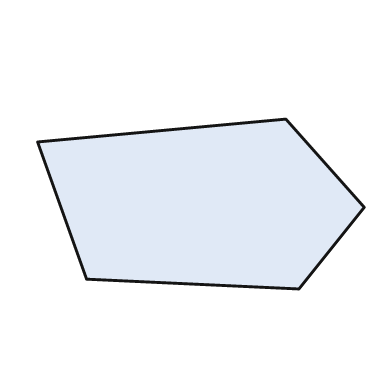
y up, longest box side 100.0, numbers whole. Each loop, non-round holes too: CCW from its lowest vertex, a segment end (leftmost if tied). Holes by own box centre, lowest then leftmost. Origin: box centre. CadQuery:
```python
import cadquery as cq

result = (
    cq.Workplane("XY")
    .moveTo(30.0, -26.0)
    .lineTo(50.0, -1.0)
    .lineTo(26.0, 26.0)
    .lineTo(-50.0, 19.0)
    .lineTo(-35.0, -23.0)
    .close()
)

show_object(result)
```